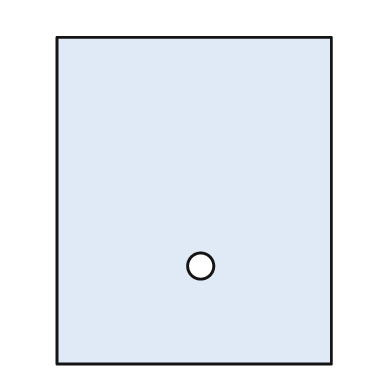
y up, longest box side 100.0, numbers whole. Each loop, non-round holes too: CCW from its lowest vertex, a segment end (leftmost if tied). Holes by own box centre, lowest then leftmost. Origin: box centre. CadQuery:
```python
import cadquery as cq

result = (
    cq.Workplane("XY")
    .moveTo(-42.0, -50.0)
    .lineTo(42.0, -50.0)
    .lineTo(42.0, 50.0)
    .lineTo(-42.0, 50.0)
    .close()
    .moveTo(2.0, -20.0)
    .circle(4.0)
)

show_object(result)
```